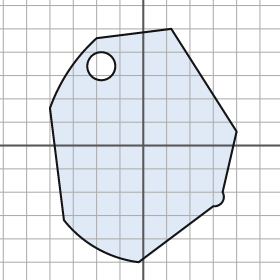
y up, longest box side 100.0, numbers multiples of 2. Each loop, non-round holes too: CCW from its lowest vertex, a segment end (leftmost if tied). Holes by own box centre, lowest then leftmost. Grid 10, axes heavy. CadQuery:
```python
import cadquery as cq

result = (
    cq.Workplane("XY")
    .moveTo(-2.0, -50.0)
    .lineTo(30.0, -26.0)
    .threePointArc((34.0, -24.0), (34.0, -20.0))
    .lineTo(40.0, 6.0)
    .lineTo(12.0, 50.0)
    .lineTo(-20.0, 46.0)
    .threePointArc((-32.0, 32.0), (-40.0, 16.0))
    .lineTo(-34.0, -32.0)
    .threePointArc((-20.0, -44.0), (-2.0, -50.0))
    .close()
    .moveTo(-18.0, 34.0)
    .circle(6.0)
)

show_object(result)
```